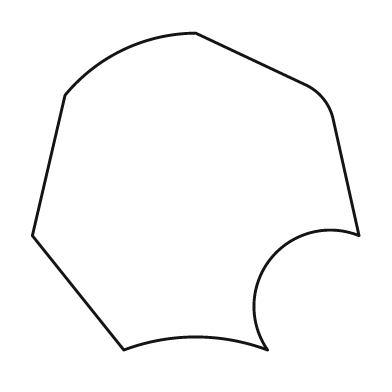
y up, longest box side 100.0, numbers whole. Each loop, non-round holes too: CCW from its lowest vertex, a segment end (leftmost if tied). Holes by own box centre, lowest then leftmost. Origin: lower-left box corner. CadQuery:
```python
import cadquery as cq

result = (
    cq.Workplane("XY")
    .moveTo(28.0, 0.0)
    .threePointArc((50.0, 4.0), (72.0, 0.0))
    .threePointArc((73.0, 28.0), (100.0, 35.0))
    .lineTo(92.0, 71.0)
    .threePointArc((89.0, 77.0), (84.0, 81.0))
    .lineTo(50.0, 97.0)
    .threePointArc((28.0, 92.0), (10.0, 78.0))
    .lineTo(0.0, 35.0)
    .close()
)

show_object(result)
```